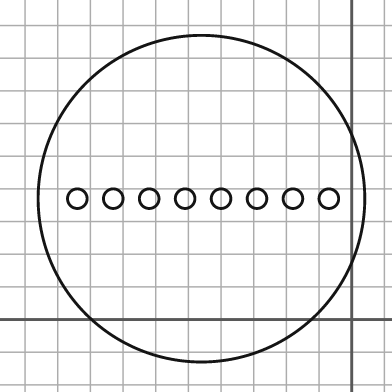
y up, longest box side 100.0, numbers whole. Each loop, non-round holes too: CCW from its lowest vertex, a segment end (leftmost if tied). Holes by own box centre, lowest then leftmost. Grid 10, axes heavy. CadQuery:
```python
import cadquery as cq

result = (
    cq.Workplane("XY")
    .moveTo(-46.0, 37.0)
    .circle(50.0)
    .moveTo(-84.0, 37.0)
    .circle(3.0)
    .moveTo(-73.0, 37.0)
    .circle(3.0)
    .moveTo(-62.0, 37.0)
    .circle(3.0)
    .moveTo(-51.0, 37.0)
    .circle(3.0)
    .moveTo(-40.0, 37.0)
    .circle(3.0)
    .moveTo(-29.0, 37.0)
    .circle(3.0)
    .moveTo(-18.0, 37.0)
    .circle(3.0)
    .moveTo(-7.0, 37.0)
    .circle(3.0)
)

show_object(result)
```